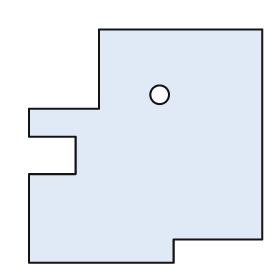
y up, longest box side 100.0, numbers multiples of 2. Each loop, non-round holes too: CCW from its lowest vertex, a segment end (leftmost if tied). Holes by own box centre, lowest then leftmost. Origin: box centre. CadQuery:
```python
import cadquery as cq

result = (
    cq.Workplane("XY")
    .moveTo(-50.0, -50.0)
    .lineTo(12.0, -50.0)
    .lineTo(12.0, -40.0)
    .lineTo(50.0, -40.0)
    .lineTo(50.0, 50.0)
    .lineTo(-20.0, 50.0)
    .lineTo(-20.0, 16.0)
    .lineTo(-50.0, 16.0)
    .lineTo(-50.0, 4.0)
    .lineTo(-30.0, 4.0)
    .lineTo(-30.0, -12.0)
    .lineTo(-50.0, -12.0)
    .close()
    .moveTo(6.0, 22.0)
    .circle(4.0)
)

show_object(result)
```